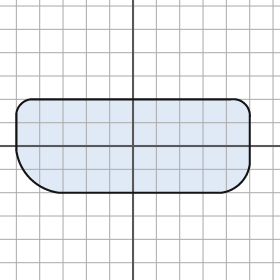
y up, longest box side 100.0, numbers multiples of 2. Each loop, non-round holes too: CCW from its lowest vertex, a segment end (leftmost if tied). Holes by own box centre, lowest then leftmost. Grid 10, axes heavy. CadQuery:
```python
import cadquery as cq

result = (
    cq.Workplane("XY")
    .moveTo(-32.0, -20.0)
    .lineTo(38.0, -20.0)
    .threePointArc((46.0, -16.0), (50.0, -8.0))
    .lineTo(50.0, 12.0)
    .threePointArc((48.0, 18.0), (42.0, 20.0))
    .lineTo(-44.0, 20.0)
    .threePointArc((-48.0, 18.0), (-50.0, 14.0))
    .lineTo(-50.0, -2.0)
    .threePointArc((-44.0, -14.0), (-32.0, -20.0))
    .close()
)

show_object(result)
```